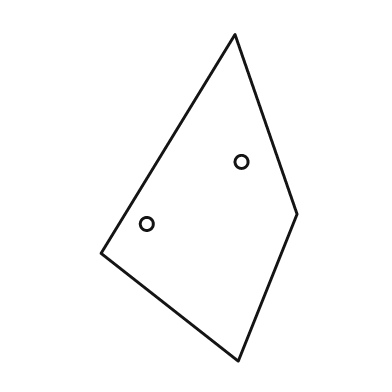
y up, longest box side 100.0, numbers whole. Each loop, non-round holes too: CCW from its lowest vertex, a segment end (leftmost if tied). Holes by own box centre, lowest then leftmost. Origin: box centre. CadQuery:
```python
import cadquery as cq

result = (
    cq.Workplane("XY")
    .moveTo(12.0, -50.0)
    .lineTo(30.0, -5.0)
    .lineTo(11.0, 50.0)
    .lineTo(-30.0, -17.0)
    .close()
    .moveTo(-16.0, -8.0)
    .circle(2.0)
    .moveTo(13.0, 11.0)
    .circle(2.0)
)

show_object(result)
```